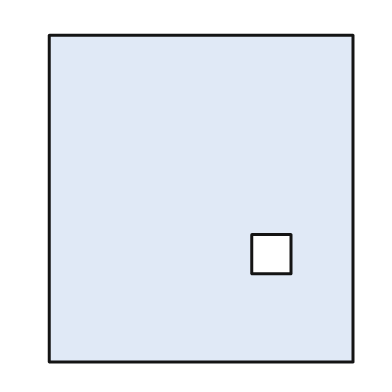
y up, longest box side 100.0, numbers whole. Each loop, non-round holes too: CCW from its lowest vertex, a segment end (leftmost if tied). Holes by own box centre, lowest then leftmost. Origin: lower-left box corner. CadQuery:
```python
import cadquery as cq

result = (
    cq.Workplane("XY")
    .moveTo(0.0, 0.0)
    .lineTo(93.0, 0.0)
    .lineTo(93.0, 100.0)
    .lineTo(0.0, 100.0)
    .close()
    .moveTo(62.0, 27.0)
    .lineTo(74.0, 27.0)
    .lineTo(74.0, 39.0)
    .lineTo(62.0, 39.0)
    .close()
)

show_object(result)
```